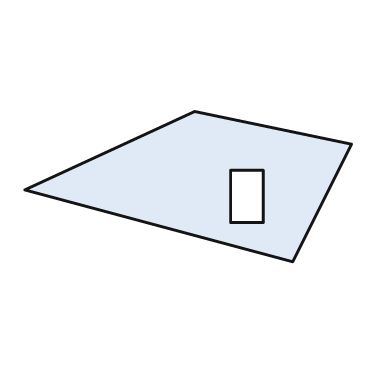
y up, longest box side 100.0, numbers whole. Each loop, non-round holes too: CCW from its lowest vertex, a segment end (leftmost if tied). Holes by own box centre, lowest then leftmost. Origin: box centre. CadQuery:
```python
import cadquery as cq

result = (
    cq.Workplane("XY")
    .moveTo(32.0, -23.0)
    .lineTo(50.0, 13.0)
    .lineTo(2.0, 23.0)
    .lineTo(-50.0, -1.0)
    .close()
    .moveTo(13.0, -11.0)
    .lineTo(23.0, -11.0)
    .lineTo(23.0, 5.0)
    .lineTo(13.0, 5.0)
    .close()
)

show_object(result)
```